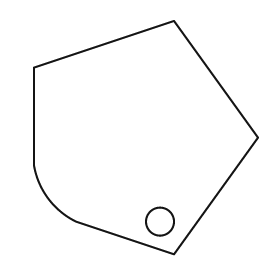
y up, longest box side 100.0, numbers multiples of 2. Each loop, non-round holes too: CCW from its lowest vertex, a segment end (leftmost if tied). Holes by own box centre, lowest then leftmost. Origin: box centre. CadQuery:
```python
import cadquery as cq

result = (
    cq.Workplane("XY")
    .moveTo(12.0, -50.0)
    .lineTo(48.0, 0.0)
    .lineTo(12.0, 50.0)
    .lineTo(-48.0, 30.0)
    .lineTo(-48.0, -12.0)
    .threePointArc((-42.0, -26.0), (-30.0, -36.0))
    .close()
    .moveTo(6.0, -36.0)
    .circle(6.0)
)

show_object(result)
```